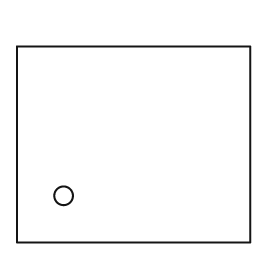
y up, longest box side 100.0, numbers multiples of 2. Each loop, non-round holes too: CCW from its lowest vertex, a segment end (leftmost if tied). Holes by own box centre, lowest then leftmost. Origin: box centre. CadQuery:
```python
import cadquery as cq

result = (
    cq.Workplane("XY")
    .moveTo(-50.0, -42.0)
    .lineTo(50.0, -42.0)
    .lineTo(50.0, 42.0)
    .lineTo(-50.0, 42.0)
    .close()
    .moveTo(-30.0, -22.0)
    .circle(4.0)
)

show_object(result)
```